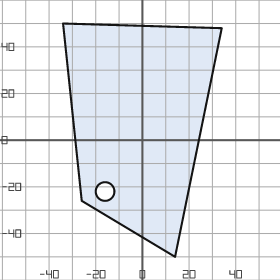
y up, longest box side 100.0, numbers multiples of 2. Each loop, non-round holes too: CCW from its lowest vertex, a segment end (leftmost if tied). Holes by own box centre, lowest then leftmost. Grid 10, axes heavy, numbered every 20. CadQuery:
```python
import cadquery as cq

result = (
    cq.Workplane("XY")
    .moveTo(14.0, -50.0)
    .lineTo(34.0, 48.0)
    .lineTo(-34.0, 50.0)
    .lineTo(-26.0, -26.0)
    .close()
    .moveTo(-16.0, -22.0)
    .circle(4.0)
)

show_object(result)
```